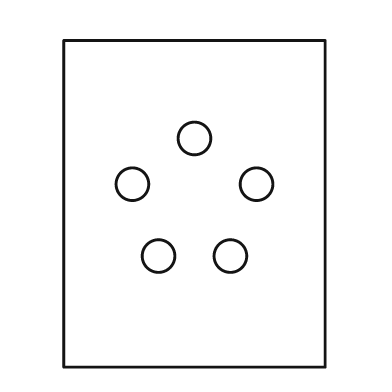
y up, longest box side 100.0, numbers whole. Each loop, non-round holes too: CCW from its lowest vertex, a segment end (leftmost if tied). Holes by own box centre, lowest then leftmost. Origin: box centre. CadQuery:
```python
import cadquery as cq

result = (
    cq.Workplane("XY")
    .moveTo(-40.0, -50.0)
    .lineTo(40.0, -50.0)
    .lineTo(40.0, 50.0)
    .lineTo(-40.0, 50.0)
    .close()
    .moveTo(-11.0, -16.0)
    .circle(5.0)
    .moveTo(11.0, -16.0)
    .circle(5.0)
    .moveTo(-19.0, 6.0)
    .circle(5.0)
    .moveTo(19.0, 6.0)
    .circle(5.0)
    .moveTo(0.0, 20.0)
    .circle(5.0)
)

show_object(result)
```